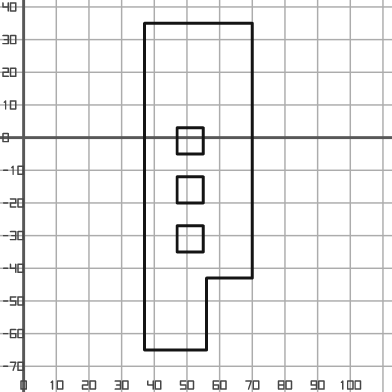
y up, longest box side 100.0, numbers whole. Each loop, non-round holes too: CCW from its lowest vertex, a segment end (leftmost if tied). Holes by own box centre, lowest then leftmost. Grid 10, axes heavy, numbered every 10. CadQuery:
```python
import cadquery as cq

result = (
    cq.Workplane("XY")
    .moveTo(37.0, -65.0)
    .lineTo(56.0, -65.0)
    .lineTo(56.0, -43.0)
    .lineTo(70.0, -43.0)
    .lineTo(70.0, 35.0)
    .lineTo(37.0, 35.0)
    .close()
    .moveTo(47.0, -35.0)
    .lineTo(55.0, -35.0)
    .lineTo(55.0, -27.0)
    .lineTo(47.0, -27.0)
    .close()
    .moveTo(47.0, -20.0)
    .lineTo(55.0, -20.0)
    .lineTo(55.0, -12.0)
    .lineTo(47.0, -12.0)
    .close()
    .moveTo(47.0, -5.0)
    .lineTo(55.0, -5.0)
    .lineTo(55.0, 3.0)
    .lineTo(47.0, 3.0)
    .close()
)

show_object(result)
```